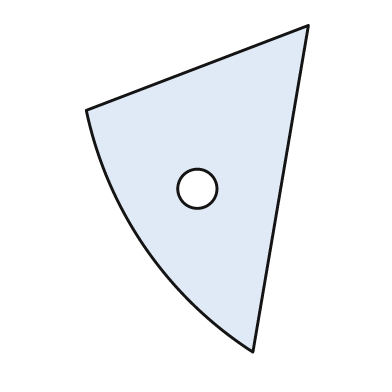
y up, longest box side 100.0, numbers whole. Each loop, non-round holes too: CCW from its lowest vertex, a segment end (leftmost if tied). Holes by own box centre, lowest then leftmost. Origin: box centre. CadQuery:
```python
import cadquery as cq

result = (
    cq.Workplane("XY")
    .moveTo(17.0, -50.0)
    .lineTo(34.0, 50.0)
    .lineTo(-34.0, 24.0)
    .threePointArc((-16.0, -18.0), (17.0, -50.0))
    .close()
    .moveTo(0.0, 0.0)
    .circle(6.0)
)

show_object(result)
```